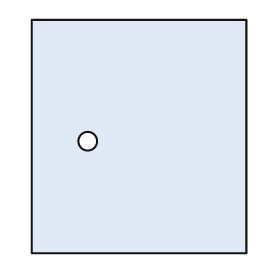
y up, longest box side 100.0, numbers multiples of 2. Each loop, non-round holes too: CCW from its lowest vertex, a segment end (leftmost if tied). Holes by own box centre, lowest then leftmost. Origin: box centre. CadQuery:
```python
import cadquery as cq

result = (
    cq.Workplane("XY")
    .moveTo(-46.0, -50.0)
    .lineTo(46.0, -50.0)
    .lineTo(46.0, 50.0)
    .lineTo(-46.0, 50.0)
    .close()
    .moveTo(-22.0, -2.0)
    .circle(4.0)
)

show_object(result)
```